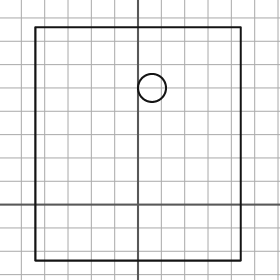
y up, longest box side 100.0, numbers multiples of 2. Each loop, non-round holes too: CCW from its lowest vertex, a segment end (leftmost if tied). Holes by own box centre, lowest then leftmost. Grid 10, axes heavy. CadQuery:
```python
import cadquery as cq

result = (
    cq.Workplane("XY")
    .moveTo(-44.0, -24.0)
    .lineTo(44.0, -24.0)
    .lineTo(44.0, 76.0)
    .lineTo(-44.0, 76.0)
    .close()
    .moveTo(6.0, 50.0)
    .circle(6.0)
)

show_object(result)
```